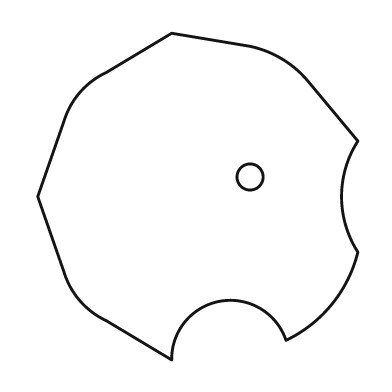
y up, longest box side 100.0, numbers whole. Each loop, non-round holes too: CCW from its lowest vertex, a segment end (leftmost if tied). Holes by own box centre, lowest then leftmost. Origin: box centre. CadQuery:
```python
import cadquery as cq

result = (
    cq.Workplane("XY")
    .moveTo(-8.0, -50.0)
    .threePointArc((7.0, -32.0), (27.0, -44.0))
    .threePointArc((41.0, -33.0), (49.0, -17.0))
    .threePointArc((44.0, 0.0), (49.0, 17.0))
    .lineTo(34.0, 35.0)
    .threePointArc((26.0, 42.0), (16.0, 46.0))
    .lineTo(-8.0, 50.0)
    .lineTo(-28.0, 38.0)
    .threePointArc((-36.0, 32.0), (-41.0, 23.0))
    .lineTo(-49.0, 0.0)
    .lineTo(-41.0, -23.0)
    .threePointArc((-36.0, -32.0), (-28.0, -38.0))
    .close()
    .moveTo(16.0, 6.0)
    .circle(4.0)
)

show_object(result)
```